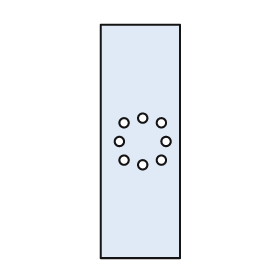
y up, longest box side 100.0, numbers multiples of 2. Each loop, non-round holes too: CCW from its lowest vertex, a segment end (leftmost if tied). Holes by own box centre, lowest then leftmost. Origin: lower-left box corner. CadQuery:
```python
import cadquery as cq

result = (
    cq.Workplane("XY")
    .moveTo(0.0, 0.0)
    .lineTo(34.0, 0.0)
    .lineTo(34.0, 100.0)
    .lineTo(0.0, 100.0)
    .close()
    .moveTo(18.0, 40.0)
    .circle(2.0)
    .moveTo(10.0, 42.0)
    .circle(2.0)
    .moveTo(26.0, 42.0)
    .circle(2.0)
    .moveTo(8.0, 50.0)
    .circle(2.0)
    .moveTo(28.0, 50.0)
    .circle(2.0)
    .moveTo(10.0, 58.0)
    .circle(2.0)
    .moveTo(26.0, 58.0)
    .circle(2.0)
    .moveTo(18.0, 60.0)
    .circle(2.0)
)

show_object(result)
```